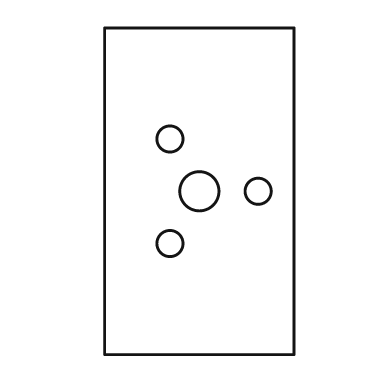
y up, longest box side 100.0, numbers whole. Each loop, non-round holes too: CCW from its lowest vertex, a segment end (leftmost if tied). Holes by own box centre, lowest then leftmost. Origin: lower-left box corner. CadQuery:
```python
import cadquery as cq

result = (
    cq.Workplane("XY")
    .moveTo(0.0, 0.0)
    .lineTo(58.0, 0.0)
    .lineTo(58.0, 100.0)
    .lineTo(0.0, 100.0)
    .close()
    .moveTo(20.0, 34.0)
    .circle(4.0)
    .moveTo(29.0, 50.0)
    .circle(6.0)
    .moveTo(47.0, 50.0)
    .circle(4.0)
    .moveTo(20.0, 66.0)
    .circle(4.0)
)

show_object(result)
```